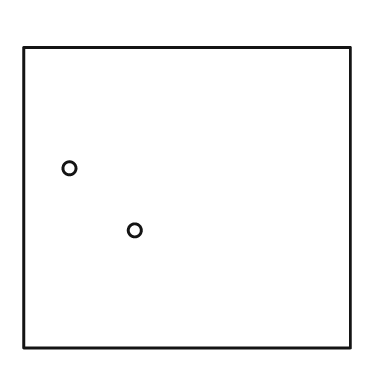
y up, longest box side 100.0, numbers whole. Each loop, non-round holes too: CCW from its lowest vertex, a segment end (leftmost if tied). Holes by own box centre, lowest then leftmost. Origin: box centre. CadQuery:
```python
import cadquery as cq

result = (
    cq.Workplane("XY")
    .moveTo(-50.0, -46.0)
    .lineTo(50.0, -46.0)
    .lineTo(50.0, 46.0)
    .lineTo(-50.0, 46.0)
    .close()
    .moveTo(-16.0, -10.0)
    .circle(2.0)
    .moveTo(-36.0, 9.0)
    .circle(2.0)
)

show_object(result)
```